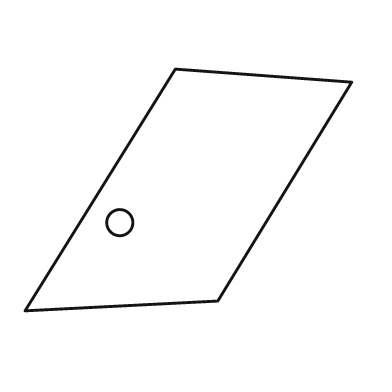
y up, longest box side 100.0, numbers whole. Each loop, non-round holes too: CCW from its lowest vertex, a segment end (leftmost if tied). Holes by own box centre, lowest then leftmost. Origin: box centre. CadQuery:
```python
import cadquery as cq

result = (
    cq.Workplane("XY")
    .moveTo(-50.0, -37.0)
    .lineTo(9.0, -34.0)
    .lineTo(50.0, 33.0)
    .lineTo(-4.0, 37.0)
    .close()
    .moveTo(-21.0, -10.0)
    .circle(4.0)
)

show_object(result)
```